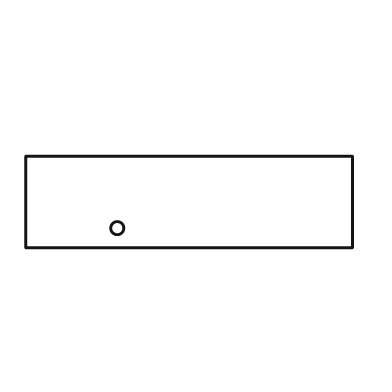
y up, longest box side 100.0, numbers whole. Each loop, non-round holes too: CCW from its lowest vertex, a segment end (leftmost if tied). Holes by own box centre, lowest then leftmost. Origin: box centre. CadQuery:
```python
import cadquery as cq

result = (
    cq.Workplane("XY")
    .moveTo(-50.0, -14.0)
    .lineTo(50.0, -14.0)
    .lineTo(50.0, 14.0)
    .lineTo(-50.0, 14.0)
    .close()
    .moveTo(-22.0, -8.0)
    .circle(2.0)
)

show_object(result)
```